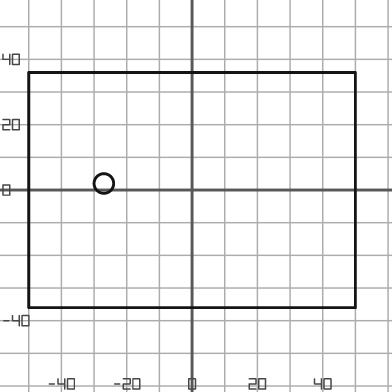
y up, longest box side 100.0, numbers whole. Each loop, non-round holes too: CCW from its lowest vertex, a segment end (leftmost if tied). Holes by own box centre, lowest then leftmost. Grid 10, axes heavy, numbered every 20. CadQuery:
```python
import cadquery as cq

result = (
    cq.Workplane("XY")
    .moveTo(-50.0, -36.0)
    .lineTo(50.0, -36.0)
    .lineTo(50.0, 36.0)
    .lineTo(-50.0, 36.0)
    .close()
    .moveTo(-27.0, 2.0)
    .circle(3.0)
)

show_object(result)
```